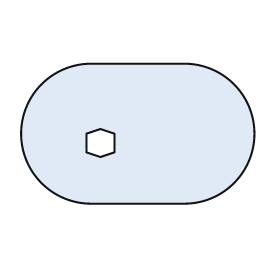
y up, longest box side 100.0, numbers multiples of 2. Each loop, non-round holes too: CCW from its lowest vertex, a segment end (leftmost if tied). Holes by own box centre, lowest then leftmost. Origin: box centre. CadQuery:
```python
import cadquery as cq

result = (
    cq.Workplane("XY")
    .moveTo(-20.0, -30.0)
    .lineTo(20.0, -30.0)
    .threePointArc((50.0, 0.0), (20.0, 30.0))
    .lineTo(-20.0, 30.0)
    .threePointArc((-50.0, 0.0), (-20.0, -30.0))
    .close()
    .moveTo(-16.0, -10.0)
    .lineTo(-10.0, -8.0)
    .lineTo(-10.0, 0.0)
    .lineTo(-16.0, 2.0)
    .lineTo(-22.0, 0.0)
    .lineTo(-22.0, -8.0)
    .close()
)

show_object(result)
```